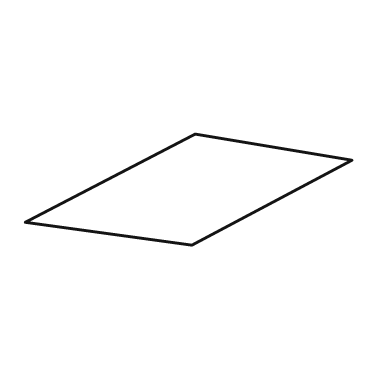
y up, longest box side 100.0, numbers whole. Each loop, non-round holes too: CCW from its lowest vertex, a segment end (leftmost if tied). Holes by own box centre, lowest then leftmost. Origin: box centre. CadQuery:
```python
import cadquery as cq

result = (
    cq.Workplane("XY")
    .moveTo(1.0, -17.0)
    .lineTo(50.0, 9.0)
    .lineTo(2.0, 17.0)
    .lineTo(-50.0, -10.0)
    .close()
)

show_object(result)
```